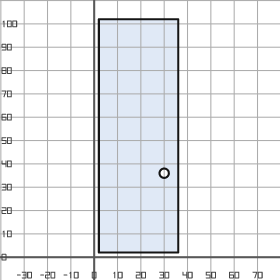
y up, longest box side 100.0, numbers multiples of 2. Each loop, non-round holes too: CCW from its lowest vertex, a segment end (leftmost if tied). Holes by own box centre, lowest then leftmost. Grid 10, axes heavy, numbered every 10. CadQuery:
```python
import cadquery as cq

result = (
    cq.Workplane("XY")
    .moveTo(2.0, 2.0)
    .lineTo(36.0, 2.0)
    .lineTo(36.0, 102.0)
    .lineTo(2.0, 102.0)
    .close()
    .moveTo(30.0, 36.0)
    .circle(2.0)
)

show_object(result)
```